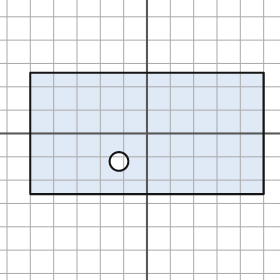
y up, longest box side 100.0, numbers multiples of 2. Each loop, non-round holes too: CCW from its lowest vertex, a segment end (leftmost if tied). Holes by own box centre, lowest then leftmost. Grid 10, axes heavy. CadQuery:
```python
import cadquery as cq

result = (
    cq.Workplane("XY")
    .moveTo(-50.0, -26.0)
    .lineTo(50.0, -26.0)
    .lineTo(50.0, 26.0)
    .lineTo(-50.0, 26.0)
    .close()
    .moveTo(-12.0, -12.0)
    .circle(4.0)
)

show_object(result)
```